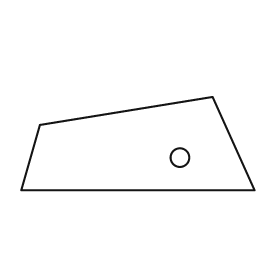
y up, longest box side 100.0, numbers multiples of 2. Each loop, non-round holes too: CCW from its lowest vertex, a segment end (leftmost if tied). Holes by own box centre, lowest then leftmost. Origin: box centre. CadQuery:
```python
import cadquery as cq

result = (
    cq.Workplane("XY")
    .moveTo(-50.0, -20.0)
    .lineTo(50.0, -20.0)
    .lineTo(32.0, 20.0)
    .lineTo(-42.0, 8.0)
    .close()
    .moveTo(18.0, -6.0)
    .circle(4.0)
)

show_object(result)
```